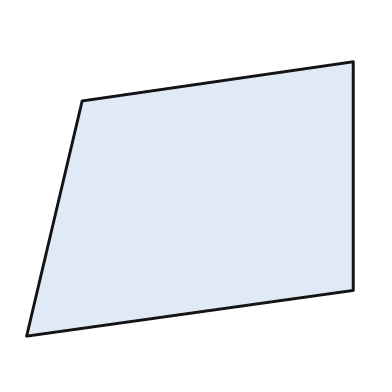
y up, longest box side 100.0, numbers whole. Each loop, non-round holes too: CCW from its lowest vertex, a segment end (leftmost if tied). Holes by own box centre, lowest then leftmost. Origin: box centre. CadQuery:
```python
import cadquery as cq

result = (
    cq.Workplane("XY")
    .moveTo(-50.0, -42.0)
    .lineTo(50.0, -28.0)
    .lineTo(50.0, 42.0)
    .lineTo(-33.0, 30.0)
    .close()
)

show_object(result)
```